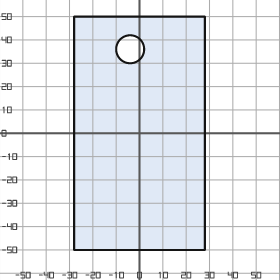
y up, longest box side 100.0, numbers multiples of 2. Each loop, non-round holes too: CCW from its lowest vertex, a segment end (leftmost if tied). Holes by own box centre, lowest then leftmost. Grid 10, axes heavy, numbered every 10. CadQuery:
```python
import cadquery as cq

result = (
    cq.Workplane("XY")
    .moveTo(-28.0, -50.0)
    .lineTo(28.0, -50.0)
    .lineTo(28.0, 50.0)
    .lineTo(-28.0, 50.0)
    .close()
    .moveTo(-4.0, 36.0)
    .circle(6.0)
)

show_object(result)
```